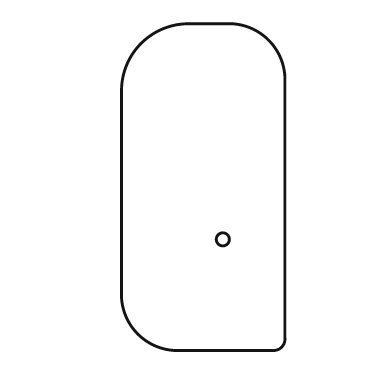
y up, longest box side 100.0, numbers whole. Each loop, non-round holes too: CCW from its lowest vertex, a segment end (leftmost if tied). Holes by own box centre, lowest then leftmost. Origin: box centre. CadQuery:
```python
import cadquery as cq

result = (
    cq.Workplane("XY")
    .moveTo(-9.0, -50.0)
    .lineTo(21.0, -50.0)
    .threePointArc((24.0, -49.0), (25.0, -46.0))
    .lineTo(25.0, 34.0)
    .threePointArc((20.0, 45.0), (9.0, 50.0))
    .lineTo(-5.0, 50.0)
    .threePointArc((-19.0, 44.0), (-25.0, 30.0))
    .lineTo(-25.0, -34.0)
    .threePointArc((-20.0, -45.0), (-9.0, -50.0))
    .close()
    .moveTo(6.0, -16.0)
    .circle(2.0)
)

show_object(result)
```